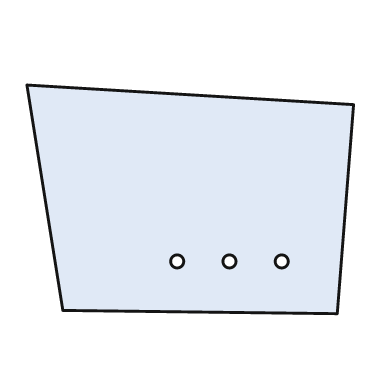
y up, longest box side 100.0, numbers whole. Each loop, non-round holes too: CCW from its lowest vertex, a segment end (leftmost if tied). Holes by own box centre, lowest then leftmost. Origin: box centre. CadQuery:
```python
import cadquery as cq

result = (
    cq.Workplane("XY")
    .moveTo(45.0, -35.0)
    .lineTo(50.0, 29.0)
    .lineTo(-50.0, 35.0)
    .lineTo(-39.0, -34.0)
    .close()
    .moveTo(-4.0, -19.0)
    .circle(2.0)
    .moveTo(12.0, -19.0)
    .circle(2.0)
    .moveTo(28.0, -19.0)
    .circle(2.0)
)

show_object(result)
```